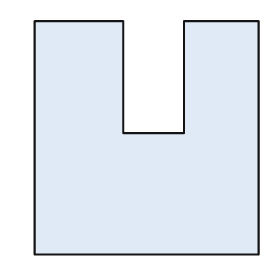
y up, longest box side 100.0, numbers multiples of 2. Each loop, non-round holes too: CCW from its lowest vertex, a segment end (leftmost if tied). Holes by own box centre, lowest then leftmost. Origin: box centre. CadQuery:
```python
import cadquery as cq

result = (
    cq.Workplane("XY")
    .moveTo(-48.0, -50.0)
    .lineTo(48.0, -50.0)
    .lineTo(48.0, 50.0)
    .lineTo(16.0, 50.0)
    .lineTo(16.0, 2.0)
    .lineTo(-10.0, 2.0)
    .lineTo(-10.0, 50.0)
    .lineTo(-48.0, 50.0)
    .close()
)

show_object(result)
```